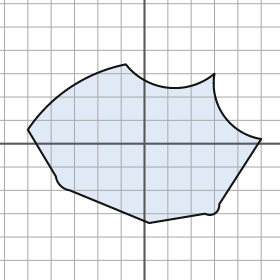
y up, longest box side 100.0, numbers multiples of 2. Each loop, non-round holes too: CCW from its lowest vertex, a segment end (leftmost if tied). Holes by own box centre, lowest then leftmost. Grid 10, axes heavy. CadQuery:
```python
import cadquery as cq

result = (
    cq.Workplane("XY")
    .moveTo(2.0, -34.0)
    .lineTo(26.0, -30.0)
    .threePointArc((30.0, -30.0), (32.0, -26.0))
    .lineTo(50.0, 2.0)
    .threePointArc((34.0, 12.0), (30.0, 30.0))
    .threePointArc((10.0, 24.0), (-8.0, 34.0))
    .threePointArc((-32.0, 24.0), (-50.0, 6.0))
    .lineTo(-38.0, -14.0)
    .threePointArc((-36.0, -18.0), (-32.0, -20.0))
    .close()
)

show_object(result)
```